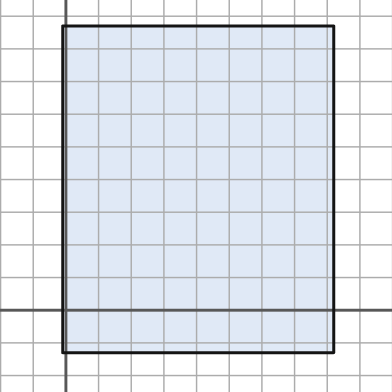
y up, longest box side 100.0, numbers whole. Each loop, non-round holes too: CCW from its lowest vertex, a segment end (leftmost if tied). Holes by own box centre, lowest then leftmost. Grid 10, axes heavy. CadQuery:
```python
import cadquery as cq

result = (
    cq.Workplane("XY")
    .moveTo(-1.0, -13.0)
    .lineTo(82.0, -13.0)
    .lineTo(82.0, 87.0)
    .lineTo(-1.0, 87.0)
    .close()
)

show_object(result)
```